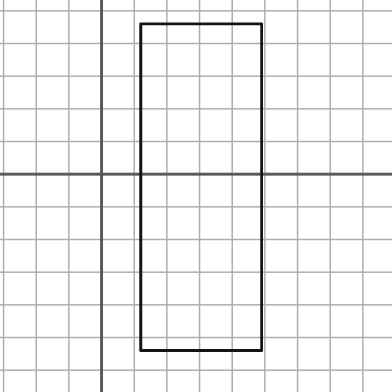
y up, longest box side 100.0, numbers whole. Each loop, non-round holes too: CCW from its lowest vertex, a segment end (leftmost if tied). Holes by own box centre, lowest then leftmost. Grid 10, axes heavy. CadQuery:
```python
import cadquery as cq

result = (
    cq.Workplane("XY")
    .moveTo(12.0, -54.0)
    .lineTo(49.0, -54.0)
    .lineTo(49.0, 46.0)
    .lineTo(12.0, 46.0)
    .close()
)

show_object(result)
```